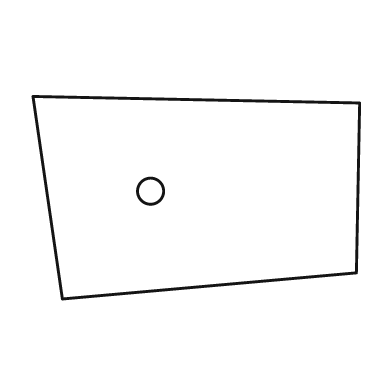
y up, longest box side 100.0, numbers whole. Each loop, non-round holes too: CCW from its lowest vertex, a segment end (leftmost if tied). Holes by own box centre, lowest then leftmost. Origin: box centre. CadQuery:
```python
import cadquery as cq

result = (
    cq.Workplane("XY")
    .moveTo(-41.0, -31.0)
    .lineTo(49.0, -23.0)
    .lineTo(50.0, 29.0)
    .lineTo(-50.0, 31.0)
    .close()
    .moveTo(-14.0, 2.0)
    .circle(4.0)
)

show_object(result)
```